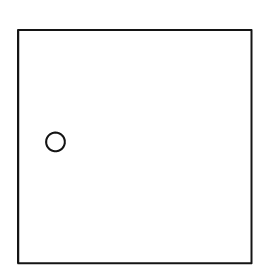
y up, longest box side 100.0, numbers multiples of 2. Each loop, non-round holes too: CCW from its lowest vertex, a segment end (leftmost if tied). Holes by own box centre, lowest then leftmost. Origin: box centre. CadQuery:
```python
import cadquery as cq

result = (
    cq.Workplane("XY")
    .moveTo(-50.0, -50.0)
    .lineTo(50.0, -50.0)
    .lineTo(50.0, 50.0)
    .lineTo(-50.0, 50.0)
    .close()
    .moveTo(-34.0, 2.0)
    .circle(4.0)
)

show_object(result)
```